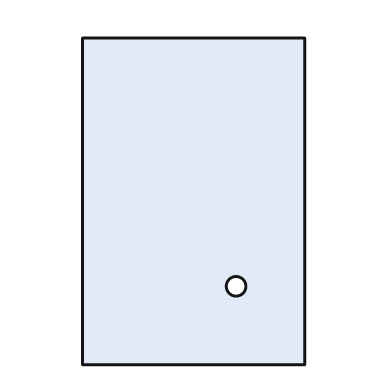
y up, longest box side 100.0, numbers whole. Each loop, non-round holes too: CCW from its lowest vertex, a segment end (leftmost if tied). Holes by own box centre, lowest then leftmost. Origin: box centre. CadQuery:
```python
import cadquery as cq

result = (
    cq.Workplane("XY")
    .moveTo(-34.0, -50.0)
    .lineTo(34.0, -50.0)
    .lineTo(34.0, 50.0)
    .lineTo(-34.0, 50.0)
    .close()
    .moveTo(13.0, -26.0)
    .circle(3.0)
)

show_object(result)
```